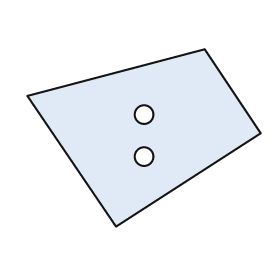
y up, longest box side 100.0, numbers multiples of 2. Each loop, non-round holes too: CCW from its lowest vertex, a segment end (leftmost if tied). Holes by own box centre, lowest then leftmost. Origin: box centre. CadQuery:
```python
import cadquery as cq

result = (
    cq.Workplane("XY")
    .moveTo(-12.0, -38.0)
    .lineTo(50.0, 2.0)
    .lineTo(26.0, 38.0)
    .lineTo(-50.0, 18.0)
    .close()
    .moveTo(0.0, -8.0)
    .circle(4.0)
    .moveTo(0.0, 10.0)
    .circle(4.0)
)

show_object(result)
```